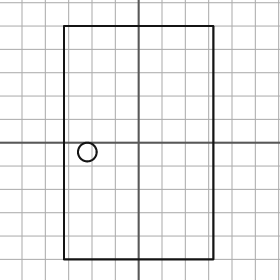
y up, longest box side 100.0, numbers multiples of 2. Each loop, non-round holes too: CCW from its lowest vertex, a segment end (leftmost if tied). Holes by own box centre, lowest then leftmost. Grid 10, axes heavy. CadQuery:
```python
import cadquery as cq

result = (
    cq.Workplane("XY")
    .moveTo(-32.0, -50.0)
    .lineTo(32.0, -50.0)
    .lineTo(32.0, 50.0)
    .lineTo(-32.0, 50.0)
    .close()
    .moveTo(-22.0, -4.0)
    .circle(4.0)
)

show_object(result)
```